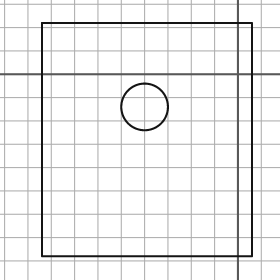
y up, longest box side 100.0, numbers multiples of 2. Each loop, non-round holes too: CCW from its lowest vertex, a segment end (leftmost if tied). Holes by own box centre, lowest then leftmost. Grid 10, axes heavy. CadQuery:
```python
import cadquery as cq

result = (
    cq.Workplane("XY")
    .moveTo(-84.0, -78.0)
    .lineTo(6.0, -78.0)
    .lineTo(6.0, 22.0)
    .lineTo(-84.0, 22.0)
    .close()
    .moveTo(-40.0, -14.0)
    .circle(10.0)
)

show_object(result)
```